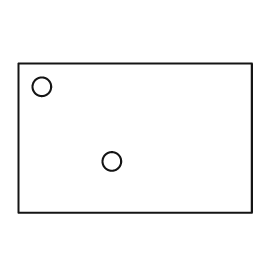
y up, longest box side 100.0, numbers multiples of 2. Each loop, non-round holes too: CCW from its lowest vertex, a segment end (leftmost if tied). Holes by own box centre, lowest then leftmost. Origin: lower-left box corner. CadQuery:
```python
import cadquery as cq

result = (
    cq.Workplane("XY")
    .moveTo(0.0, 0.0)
    .lineTo(100.0, 0.0)
    .lineTo(100.0, 64.0)
    .lineTo(0.0, 64.0)
    .close()
    .moveTo(40.0, 22.0)
    .circle(4.0)
    .moveTo(10.0, 54.0)
    .circle(4.0)
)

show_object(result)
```